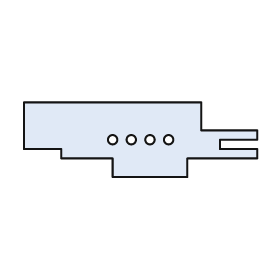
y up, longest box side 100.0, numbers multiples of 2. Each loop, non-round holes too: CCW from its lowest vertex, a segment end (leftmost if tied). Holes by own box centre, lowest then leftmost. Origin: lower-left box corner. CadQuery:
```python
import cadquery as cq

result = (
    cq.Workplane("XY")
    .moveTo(38.0, 0.0)
    .lineTo(70.0, 0.0)
    .lineTo(70.0, 8.0)
    .lineTo(100.0, 8.0)
    .lineTo(100.0, 12.0)
    .lineTo(84.0, 12.0)
    .lineTo(84.0, 16.0)
    .lineTo(100.0, 16.0)
    .lineTo(100.0, 20.0)
    .lineTo(76.0, 20.0)
    .lineTo(76.0, 32.0)
    .lineTo(0.0, 32.0)
    .lineTo(0.0, 12.0)
    .lineTo(16.0, 12.0)
    .lineTo(16.0, 8.0)
    .lineTo(38.0, 8.0)
    .close()
    .moveTo(38.0, 16.0)
    .circle(2.0)
    .moveTo(46.0, 16.0)
    .circle(2.0)
    .moveTo(54.0, 16.0)
    .circle(2.0)
    .moveTo(62.0, 16.0)
    .circle(2.0)
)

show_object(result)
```